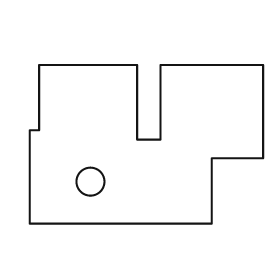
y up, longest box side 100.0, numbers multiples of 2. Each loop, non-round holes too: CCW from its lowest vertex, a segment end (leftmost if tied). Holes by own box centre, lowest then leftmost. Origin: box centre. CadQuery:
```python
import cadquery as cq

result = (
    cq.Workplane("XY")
    .moveTo(-50.0, -34.0)
    .lineTo(28.0, -34.0)
    .lineTo(28.0, -6.0)
    .lineTo(50.0, -6.0)
    .lineTo(50.0, 34.0)
    .lineTo(6.0, 34.0)
    .lineTo(6.0, 2.0)
    .lineTo(-4.0, 2.0)
    .lineTo(-4.0, 34.0)
    .lineTo(-46.0, 34.0)
    .lineTo(-46.0, 6.0)
    .lineTo(-50.0, 6.0)
    .close()
    .moveTo(-24.0, -16.0)
    .circle(6.0)
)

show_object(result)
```